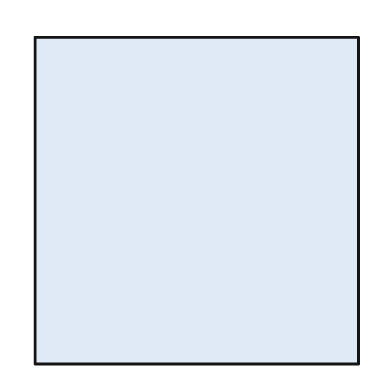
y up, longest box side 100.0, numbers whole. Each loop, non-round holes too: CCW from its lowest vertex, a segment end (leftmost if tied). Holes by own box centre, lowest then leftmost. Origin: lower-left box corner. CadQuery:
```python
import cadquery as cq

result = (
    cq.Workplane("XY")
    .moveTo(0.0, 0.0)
    .lineTo(99.0, 0.0)
    .lineTo(99.0, 100.0)
    .lineTo(0.0, 100.0)
    .close()
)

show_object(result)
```